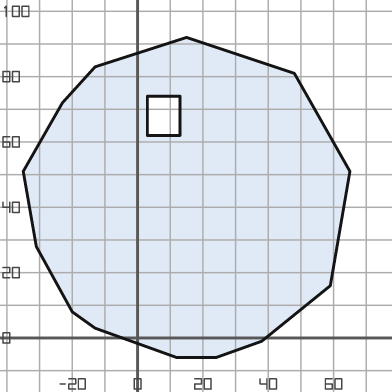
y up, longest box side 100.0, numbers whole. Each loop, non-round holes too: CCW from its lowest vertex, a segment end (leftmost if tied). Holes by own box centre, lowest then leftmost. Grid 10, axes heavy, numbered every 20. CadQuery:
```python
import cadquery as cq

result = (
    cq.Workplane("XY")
    .moveTo(12.0, -6.0)
    .lineTo(24.0, -6.0)
    .lineTo(38.0, -1.0)
    .lineTo(59.0, 16.0)
    .lineTo(65.0, 51.0)
    .lineTo(48.0, 81.0)
    .lineTo(15.0, 92.0)
    .lineTo(-13.0, 83.0)
    .lineTo(-23.0, 72.0)
    .lineTo(-35.0, 51.0)
    .lineTo(-31.0, 28.0)
    .lineTo(-20.0, 8.0)
    .lineTo(-13.0, 3.0)
    .close()
    .moveTo(3.0, 62.0)
    .lineTo(13.0, 62.0)
    .lineTo(13.0, 74.0)
    .lineTo(3.0, 74.0)
    .close()
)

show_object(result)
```